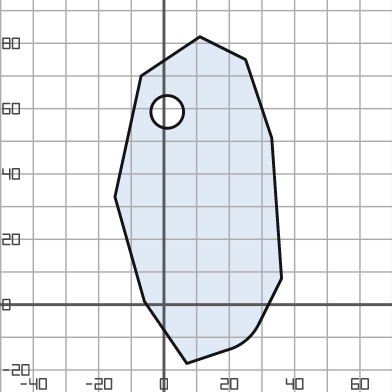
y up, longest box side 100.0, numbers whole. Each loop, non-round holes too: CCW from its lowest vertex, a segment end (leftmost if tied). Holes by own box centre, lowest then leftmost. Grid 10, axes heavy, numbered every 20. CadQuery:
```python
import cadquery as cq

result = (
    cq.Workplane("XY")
    .moveTo(7.0, -18.0)
    .lineTo(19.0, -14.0)
    .threePointArc((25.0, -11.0), (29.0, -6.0))
    .lineTo(36.0, 8.0)
    .lineTo(33.0, 51.0)
    .lineTo(25.0, 75.0)
    .lineTo(11.0, 82.0)
    .lineTo(-7.0, 70.0)
    .lineTo(-15.0, 33.0)
    .lineTo(-6.0, 1.0)
    .close()
    .moveTo(1.0, 59.0)
    .circle(5.0)
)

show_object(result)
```